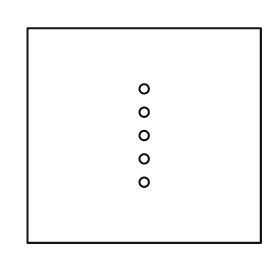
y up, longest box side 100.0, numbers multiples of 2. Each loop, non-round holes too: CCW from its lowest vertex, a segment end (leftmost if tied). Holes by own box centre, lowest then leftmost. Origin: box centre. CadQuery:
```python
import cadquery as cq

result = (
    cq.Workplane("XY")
    .moveTo(-50.0, -46.0)
    .lineTo(50.0, -46.0)
    .lineTo(50.0, 46.0)
    .lineTo(-50.0, 46.0)
    .close()
    .moveTo(0.0, -20.0)
    .circle(2.0)
    .moveTo(0.0, -10.0)
    .circle(2.0)
    .moveTo(0.0, 0.0)
    .circle(2.0)
    .moveTo(0.0, 10.0)
    .circle(2.0)
    .moveTo(0.0, 20.0)
    .circle(2.0)
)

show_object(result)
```